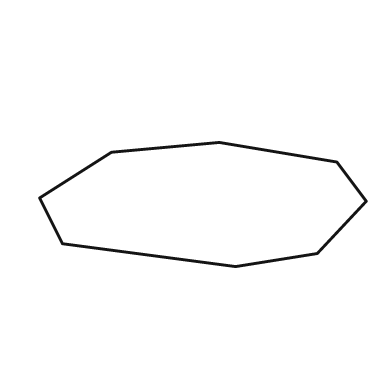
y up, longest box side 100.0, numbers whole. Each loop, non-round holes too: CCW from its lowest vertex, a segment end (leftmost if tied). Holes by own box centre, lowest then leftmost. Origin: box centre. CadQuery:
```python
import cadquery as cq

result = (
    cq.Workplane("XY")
    .moveTo(10.0, -19.0)
    .lineTo(35.0, -15.0)
    .lineTo(50.0, 1.0)
    .lineTo(41.0, 13.0)
    .lineTo(5.0, 19.0)
    .lineTo(-28.0, 16.0)
    .lineTo(-50.0, 2.0)
    .lineTo(-43.0, -12.0)
    .close()
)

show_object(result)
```